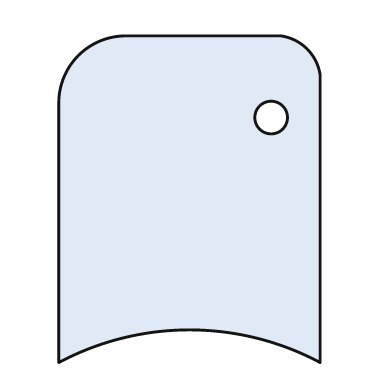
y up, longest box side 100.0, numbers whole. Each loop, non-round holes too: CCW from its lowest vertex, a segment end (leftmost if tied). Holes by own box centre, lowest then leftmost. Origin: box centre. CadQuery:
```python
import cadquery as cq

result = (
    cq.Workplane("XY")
    .moveTo(-40.0, -50.0)
    .threePointArc((0.0, -40.0), (40.0, -50.0))
    .lineTo(40.0, 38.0)
    .threePointArc((36.0, 46.0), (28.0, 50.0))
    .lineTo(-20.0, 50.0)
    .threePointArc((-34.0, 44.0), (-40.0, 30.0))
    .close()
    .moveTo(25.0, 25.0)
    .circle(5.0)
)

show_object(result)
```